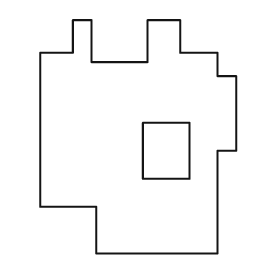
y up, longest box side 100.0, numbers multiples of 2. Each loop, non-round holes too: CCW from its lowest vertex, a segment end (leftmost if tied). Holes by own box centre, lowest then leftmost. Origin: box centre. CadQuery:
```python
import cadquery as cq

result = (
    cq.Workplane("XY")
    .moveTo(-18.0, -50.0)
    .lineTo(34.0, -50.0)
    .lineTo(34.0, -6.0)
    .lineTo(42.0, -6.0)
    .lineTo(42.0, 26.0)
    .lineTo(34.0, 26.0)
    .lineTo(34.0, 36.0)
    .lineTo(18.0, 36.0)
    .lineTo(18.0, 50.0)
    .lineTo(4.0, 50.0)
    .lineTo(4.0, 32.0)
    .lineTo(-20.0, 32.0)
    .lineTo(-20.0, 50.0)
    .lineTo(-28.0, 50.0)
    .lineTo(-28.0, 36.0)
    .lineTo(-42.0, 36.0)
    .lineTo(-42.0, -30.0)
    .lineTo(-18.0, -30.0)
    .close()
    .moveTo(2.0, -18.0)
    .lineTo(22.0, -18.0)
    .lineTo(22.0, 6.0)
    .lineTo(2.0, 6.0)
    .close()
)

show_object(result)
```